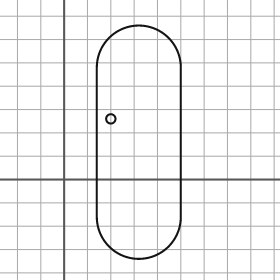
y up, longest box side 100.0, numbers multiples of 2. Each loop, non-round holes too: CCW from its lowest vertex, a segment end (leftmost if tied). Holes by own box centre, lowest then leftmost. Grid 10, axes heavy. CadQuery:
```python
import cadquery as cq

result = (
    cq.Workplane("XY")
    .moveTo(14.0, -16.0)
    .threePointArc((32.0, -34.0), (50.0, -16.0))
    .lineTo(50.0, 48.0)
    .threePointArc((32.0, 66.0), (14.0, 48.0))
    .close()
    .moveTo(20.0, 26.0)
    .circle(2.0)
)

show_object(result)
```